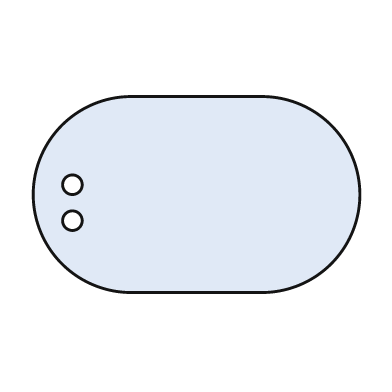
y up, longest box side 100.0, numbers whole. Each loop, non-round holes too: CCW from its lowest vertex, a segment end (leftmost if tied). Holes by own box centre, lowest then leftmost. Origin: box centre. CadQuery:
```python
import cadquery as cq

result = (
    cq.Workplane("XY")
    .moveTo(-20.0, -30.0)
    .lineTo(20.0, -30.0)
    .threePointArc((50.0, 0.0), (20.0, 30.0))
    .lineTo(-20.0, 30.0)
    .threePointArc((-50.0, 0.0), (-20.0, -30.0))
    .close()
    .moveTo(-38.0, -8.0)
    .circle(3.0)
    .moveTo(-38.0, 3.0)
    .circle(3.0)
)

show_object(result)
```